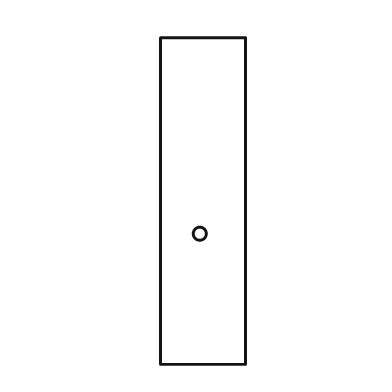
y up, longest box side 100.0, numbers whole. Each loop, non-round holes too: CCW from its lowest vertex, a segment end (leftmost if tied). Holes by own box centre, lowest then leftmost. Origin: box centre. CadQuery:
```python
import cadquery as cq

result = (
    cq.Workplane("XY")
    .moveTo(-13.0, -50.0)
    .lineTo(13.0, -50.0)
    .lineTo(13.0, 50.0)
    .lineTo(-13.0, 50.0)
    .close()
    .moveTo(-1.0, -10.0)
    .circle(2.0)
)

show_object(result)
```